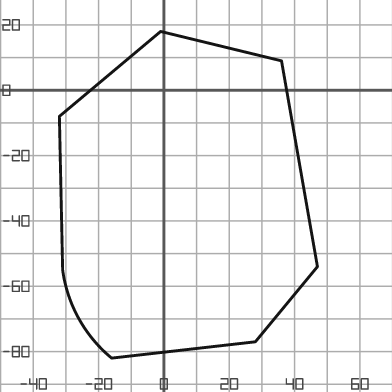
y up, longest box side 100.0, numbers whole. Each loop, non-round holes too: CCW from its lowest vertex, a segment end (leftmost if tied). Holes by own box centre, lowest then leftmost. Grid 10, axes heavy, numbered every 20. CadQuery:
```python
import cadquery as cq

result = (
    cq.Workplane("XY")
    .moveTo(-16.0, -82.0)
    .lineTo(28.0, -77.0)
    .lineTo(47.0, -54.0)
    .lineTo(36.0, 9.0)
    .lineTo(-1.0, 18.0)
    .lineTo(-32.0, -8.0)
    .lineTo(-31.0, -55.0)
    .threePointArc((-26.0, -70.0), (-16.0, -82.0))
    .close()
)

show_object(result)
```